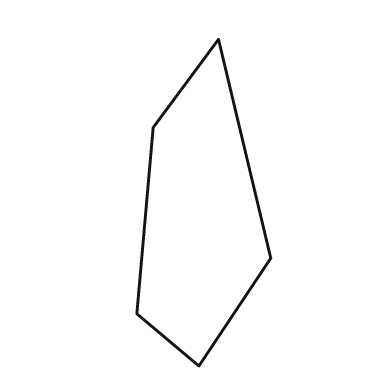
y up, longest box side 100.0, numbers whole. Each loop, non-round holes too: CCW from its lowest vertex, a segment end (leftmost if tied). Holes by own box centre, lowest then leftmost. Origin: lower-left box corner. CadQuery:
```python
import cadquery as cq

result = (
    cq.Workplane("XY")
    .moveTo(19.0, 0.0)
    .lineTo(41.0, 33.0)
    .lineTo(25.0, 100.0)
    .lineTo(5.0, 73.0)
    .lineTo(0.0, 16.0)
    .close()
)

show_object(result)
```